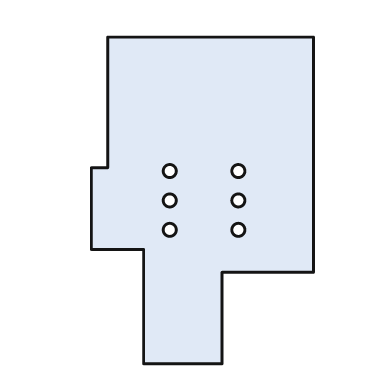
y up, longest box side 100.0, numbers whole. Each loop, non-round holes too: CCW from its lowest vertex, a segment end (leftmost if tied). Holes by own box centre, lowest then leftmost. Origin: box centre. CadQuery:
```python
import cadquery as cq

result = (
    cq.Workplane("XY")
    .moveTo(-18.0, -50.0)
    .lineTo(6.0, -50.0)
    .lineTo(6.0, -22.0)
    .lineTo(34.0, -22.0)
    .lineTo(34.0, 50.0)
    .lineTo(-29.0, 50.0)
    .lineTo(-29.0, 10.0)
    .lineTo(-34.0, 10.0)
    .lineTo(-34.0, -15.0)
    .lineTo(-18.0, -15.0)
    .close()
    .moveTo(-10.0, -9.0)
    .circle(2.0)
    .moveTo(11.0, -9.0)
    .circle(2.0)
    .moveTo(-10.0, 0.0)
    .circle(2.0)
    .moveTo(11.0, 0.0)
    .circle(2.0)
    .moveTo(-10.0, 9.0)
    .circle(2.0)
    .moveTo(11.0, 9.0)
    .circle(2.0)
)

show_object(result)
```